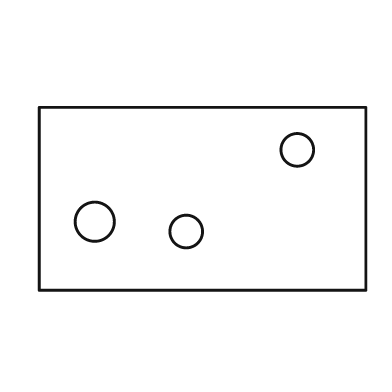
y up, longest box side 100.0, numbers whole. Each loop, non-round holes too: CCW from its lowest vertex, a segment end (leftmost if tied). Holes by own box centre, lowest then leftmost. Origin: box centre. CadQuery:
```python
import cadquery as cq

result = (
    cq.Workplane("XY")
    .moveTo(-50.0, -28.0)
    .lineTo(50.0, -28.0)
    .lineTo(50.0, 28.0)
    .lineTo(-50.0, 28.0)
    .close()
    .moveTo(-5.0, -10.0)
    .circle(5.0)
    .moveTo(-33.0, -7.0)
    .circle(6.0)
    .moveTo(29.0, 15.0)
    .circle(5.0)
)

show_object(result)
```